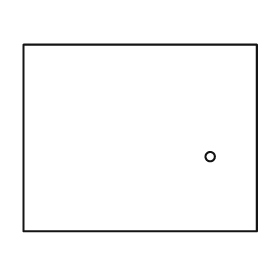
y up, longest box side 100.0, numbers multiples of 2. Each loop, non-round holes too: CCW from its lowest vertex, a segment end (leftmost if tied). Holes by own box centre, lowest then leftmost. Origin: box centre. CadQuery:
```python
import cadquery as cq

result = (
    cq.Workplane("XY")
    .moveTo(-50.0, -40.0)
    .lineTo(50.0, -40.0)
    .lineTo(50.0, 40.0)
    .lineTo(-50.0, 40.0)
    .close()
    .moveTo(30.0, -8.0)
    .circle(2.0)
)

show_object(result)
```